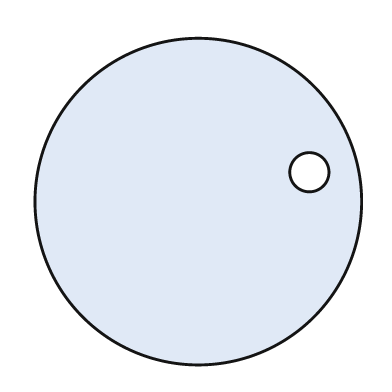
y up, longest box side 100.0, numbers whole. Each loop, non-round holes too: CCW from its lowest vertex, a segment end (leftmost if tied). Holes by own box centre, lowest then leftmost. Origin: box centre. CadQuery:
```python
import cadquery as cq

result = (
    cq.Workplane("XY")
    .moveTo(0.0, 0.0)
    .circle(50.0)
    .moveTo(34.0, 9.0)
    .circle(6.0)
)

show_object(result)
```